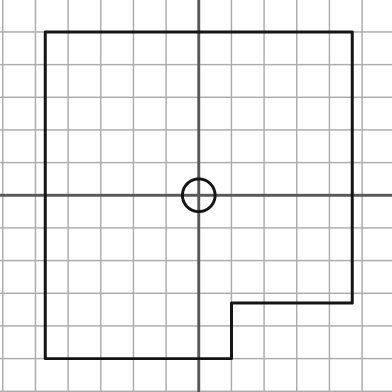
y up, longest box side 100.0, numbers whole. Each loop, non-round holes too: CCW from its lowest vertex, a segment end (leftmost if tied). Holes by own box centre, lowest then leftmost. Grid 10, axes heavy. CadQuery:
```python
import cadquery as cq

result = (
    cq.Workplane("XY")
    .moveTo(-47.0, -50.0)
    .lineTo(10.0, -50.0)
    .lineTo(10.0, -33.0)
    .lineTo(47.0, -33.0)
    .lineTo(47.0, 50.0)
    .lineTo(-47.0, 50.0)
    .close()
    .moveTo(0.0, 0.0)
    .circle(5.0)
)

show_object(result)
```